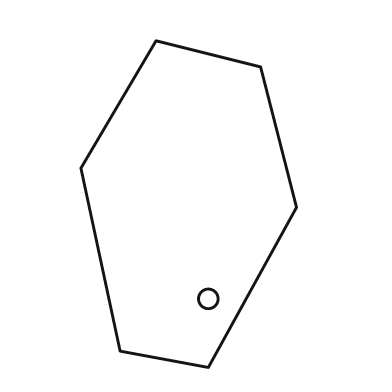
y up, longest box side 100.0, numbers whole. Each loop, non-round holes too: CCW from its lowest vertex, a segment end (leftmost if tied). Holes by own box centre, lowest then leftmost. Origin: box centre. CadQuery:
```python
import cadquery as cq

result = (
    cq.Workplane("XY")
    .moveTo(6.0, -50.0)
    .lineTo(33.0, -1.0)
    .lineTo(22.0, 42.0)
    .lineTo(-10.0, 50.0)
    .lineTo(-33.0, 11.0)
    .lineTo(-21.0, -45.0)
    .close()
    .moveTo(6.0, -29.0)
    .circle(3.0)
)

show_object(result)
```